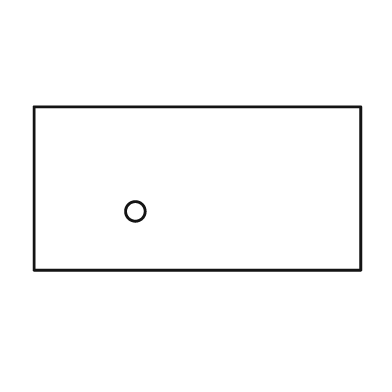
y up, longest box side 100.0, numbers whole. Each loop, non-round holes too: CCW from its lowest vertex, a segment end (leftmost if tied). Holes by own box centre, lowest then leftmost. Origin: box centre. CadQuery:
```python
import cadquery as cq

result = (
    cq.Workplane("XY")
    .moveTo(-50.0, -25.0)
    .lineTo(50.0, -25.0)
    .lineTo(50.0, 25.0)
    .lineTo(-50.0, 25.0)
    .close()
    .moveTo(-19.0, -7.0)
    .circle(3.0)
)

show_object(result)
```